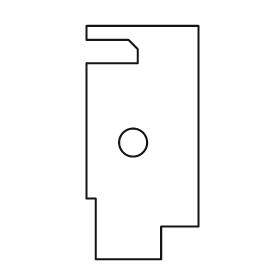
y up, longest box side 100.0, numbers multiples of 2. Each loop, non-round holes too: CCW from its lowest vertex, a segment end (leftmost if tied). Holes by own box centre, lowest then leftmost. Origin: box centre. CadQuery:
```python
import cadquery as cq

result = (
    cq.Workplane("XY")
    .moveTo(-20.0, -50.0)
    .lineTo(8.0, -50.0)
    .lineTo(8.0, -36.0)
    .lineTo(24.0, -36.0)
    .lineTo(24.0, 50.0)
    .lineTo(-24.0, 50.0)
    .lineTo(-24.0, 44.0)
    .lineTo(-6.0, 44.0)
    .lineTo(-2.0, 40.0)
    .lineTo(-2.0, 34.0)
    .lineTo(-24.0, 34.0)
    .lineTo(-24.0, -24.0)
    .lineTo(-20.0, -24.0)
    .close()
    .moveTo(-4.0, 0.0)
    .circle(6.0)
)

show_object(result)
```